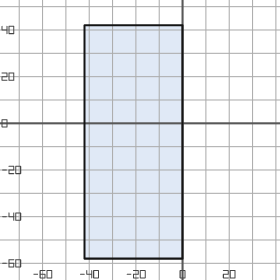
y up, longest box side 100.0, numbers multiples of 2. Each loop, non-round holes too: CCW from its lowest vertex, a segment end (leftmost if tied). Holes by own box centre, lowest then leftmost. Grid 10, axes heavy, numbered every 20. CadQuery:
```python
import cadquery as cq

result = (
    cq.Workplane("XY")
    .moveTo(-42.0, -58.0)
    .lineTo(0.0, -58.0)
    .lineTo(0.0, 42.0)
    .lineTo(-42.0, 42.0)
    .close()
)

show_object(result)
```